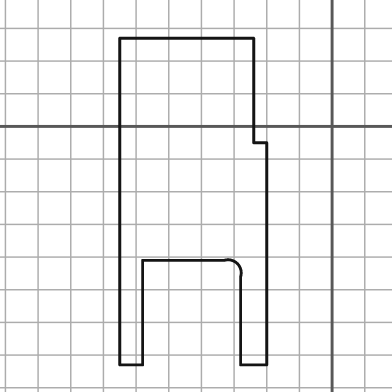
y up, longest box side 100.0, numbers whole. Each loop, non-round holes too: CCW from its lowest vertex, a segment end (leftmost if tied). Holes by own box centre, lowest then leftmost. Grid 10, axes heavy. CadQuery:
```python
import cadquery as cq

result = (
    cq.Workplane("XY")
    .moveTo(-65.0, -73.0)
    .lineTo(-58.0, -73.0)
    .lineTo(-58.0, -41.0)
    .lineTo(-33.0, -41.0)
    .threePointArc((-29.0, -42.0), (-28.0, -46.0))
    .lineTo(-28.0, -73.0)
    .lineTo(-20.0, -73.0)
    .lineTo(-20.0, -5.0)
    .lineTo(-24.0, -5.0)
    .lineTo(-24.0, 27.0)
    .lineTo(-65.0, 27.0)
    .close()
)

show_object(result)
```